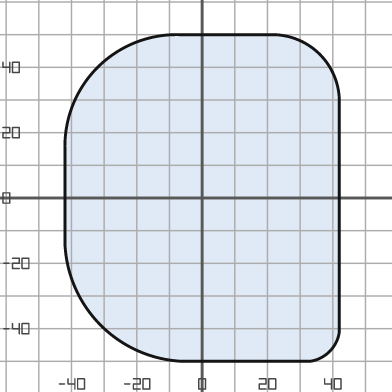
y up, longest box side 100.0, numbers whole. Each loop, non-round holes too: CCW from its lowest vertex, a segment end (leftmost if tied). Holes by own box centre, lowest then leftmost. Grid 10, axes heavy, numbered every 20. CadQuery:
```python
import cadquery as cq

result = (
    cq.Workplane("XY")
    .moveTo(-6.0, -50.0)
    .lineTo(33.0, -50.0)
    .threePointArc((39.0, -47.0), (42.0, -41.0))
    .lineTo(42.0, 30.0)
    .threePointArc((36.0, 44.0), (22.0, 50.0))
    .lineTo(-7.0, 50.0)
    .threePointArc((-32.0, 40.0), (-42.0, 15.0))
    .lineTo(-42.0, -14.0)
    .threePointArc((-31.0, -39.0), (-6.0, -50.0))
    .close()
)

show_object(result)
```